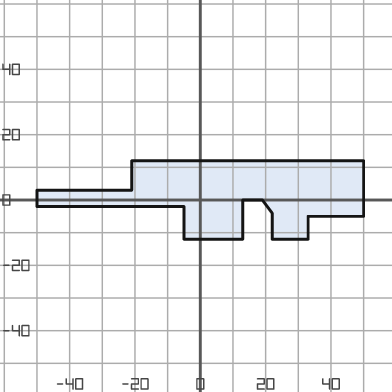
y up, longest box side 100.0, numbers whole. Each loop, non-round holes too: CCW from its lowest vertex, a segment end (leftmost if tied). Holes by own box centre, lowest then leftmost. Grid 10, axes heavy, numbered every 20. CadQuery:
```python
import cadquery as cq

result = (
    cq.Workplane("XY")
    .moveTo(-5.0, -12.0)
    .lineTo(13.0, -12.0)
    .lineTo(13.0, 0.0)
    .lineTo(19.0, 0.0)
    .lineTo(22.0, -4.0)
    .lineTo(22.0, -12.0)
    .lineTo(33.0, -12.0)
    .lineTo(33.0, -5.0)
    .lineTo(50.0, -5.0)
    .lineTo(50.0, 12.0)
    .lineTo(-21.0, 12.0)
    .lineTo(-21.0, 3.0)
    .lineTo(-50.0, 3.0)
    .lineTo(-50.0, -2.0)
    .lineTo(-5.0, -2.0)
    .close()
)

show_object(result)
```